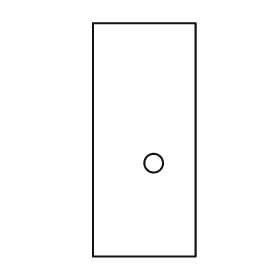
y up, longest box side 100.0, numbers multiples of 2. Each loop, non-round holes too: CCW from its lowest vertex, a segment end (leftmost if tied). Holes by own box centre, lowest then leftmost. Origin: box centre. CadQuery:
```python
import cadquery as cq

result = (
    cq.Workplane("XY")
    .moveTo(-22.0, -50.0)
    .lineTo(22.0, -50.0)
    .lineTo(22.0, 50.0)
    .lineTo(-22.0, 50.0)
    .close()
    .moveTo(4.0, -10.0)
    .circle(4.0)
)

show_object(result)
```